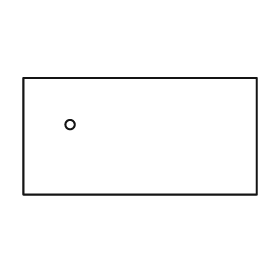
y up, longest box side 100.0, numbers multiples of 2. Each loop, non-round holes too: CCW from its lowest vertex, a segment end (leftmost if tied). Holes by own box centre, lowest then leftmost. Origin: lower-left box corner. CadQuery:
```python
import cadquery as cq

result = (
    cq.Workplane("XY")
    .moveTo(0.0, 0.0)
    .lineTo(100.0, 0.0)
    .lineTo(100.0, 50.0)
    .lineTo(0.0, 50.0)
    .close()
    .moveTo(20.0, 30.0)
    .circle(2.0)
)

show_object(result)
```